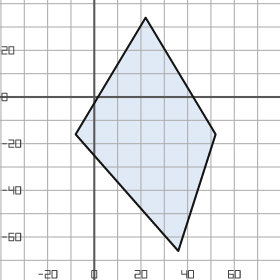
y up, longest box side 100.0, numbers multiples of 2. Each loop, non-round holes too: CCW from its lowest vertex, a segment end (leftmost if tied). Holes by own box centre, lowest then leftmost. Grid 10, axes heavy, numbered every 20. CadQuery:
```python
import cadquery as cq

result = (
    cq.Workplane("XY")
    .moveTo(36.0, -66.0)
    .lineTo(52.0, -16.0)
    .lineTo(22.0, 34.0)
    .lineTo(-8.0, -16.0)
    .close()
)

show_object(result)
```